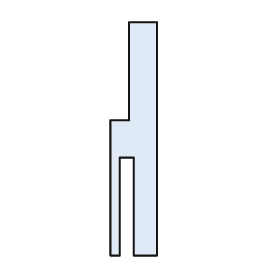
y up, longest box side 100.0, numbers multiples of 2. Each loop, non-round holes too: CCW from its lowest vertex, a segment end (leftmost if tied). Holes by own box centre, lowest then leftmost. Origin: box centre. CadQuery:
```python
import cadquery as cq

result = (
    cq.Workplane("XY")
    .moveTo(-10.0, -50.0)
    .lineTo(-6.0, -50.0)
    .lineTo(-6.0, -8.0)
    .lineTo(0.0, -8.0)
    .lineTo(0.0, -50.0)
    .lineTo(10.0, -50.0)
    .lineTo(10.0, 50.0)
    .lineTo(-2.0, 50.0)
    .lineTo(-2.0, 8.0)
    .lineTo(-10.0, 8.0)
    .close()
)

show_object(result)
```